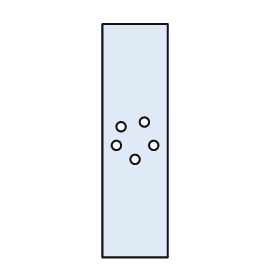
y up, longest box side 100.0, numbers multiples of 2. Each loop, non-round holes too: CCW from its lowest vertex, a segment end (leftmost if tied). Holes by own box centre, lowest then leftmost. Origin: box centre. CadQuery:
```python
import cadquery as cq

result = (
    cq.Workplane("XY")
    .moveTo(-14.0, -50.0)
    .lineTo(14.0, -50.0)
    .lineTo(14.0, 50.0)
    .lineTo(-14.0, 50.0)
    .close()
    .moveTo(0.0, -8.0)
    .circle(2.0)
    .moveTo(-8.0, -2.0)
    .circle(2.0)
    .moveTo(8.0, -2.0)
    .circle(2.0)
    .moveTo(-6.0, 6.0)
    .circle(2.0)
    .moveTo(4.0, 8.0)
    .circle(2.0)
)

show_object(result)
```